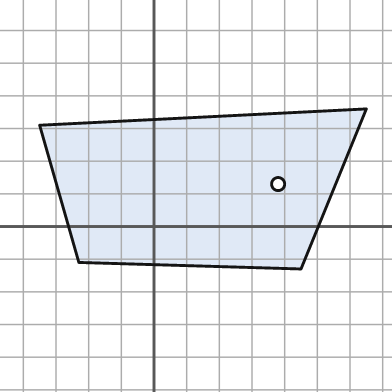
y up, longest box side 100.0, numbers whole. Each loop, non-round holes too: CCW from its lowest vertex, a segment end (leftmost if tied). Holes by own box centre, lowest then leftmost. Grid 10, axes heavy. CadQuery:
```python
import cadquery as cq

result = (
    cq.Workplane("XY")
    .moveTo(45.0, -13.0)
    .lineTo(65.0, 36.0)
    .lineTo(-35.0, 31.0)
    .lineTo(-23.0, -11.0)
    .close()
    .moveTo(38.0, 13.0)
    .circle(2.0)
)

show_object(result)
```